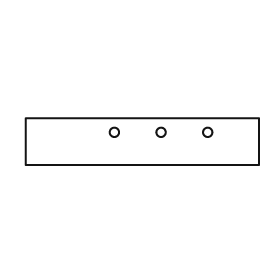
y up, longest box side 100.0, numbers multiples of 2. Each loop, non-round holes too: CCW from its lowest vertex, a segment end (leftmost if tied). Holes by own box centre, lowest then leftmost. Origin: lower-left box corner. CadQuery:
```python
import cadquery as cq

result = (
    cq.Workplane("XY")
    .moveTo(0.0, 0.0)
    .lineTo(100.0, 0.0)
    .lineTo(100.0, 20.0)
    .lineTo(0.0, 20.0)
    .close()
    .moveTo(38.0, 14.0)
    .circle(2.0)
    .moveTo(58.0, 14.0)
    .circle(2.0)
    .moveTo(78.0, 14.0)
    .circle(2.0)
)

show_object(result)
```